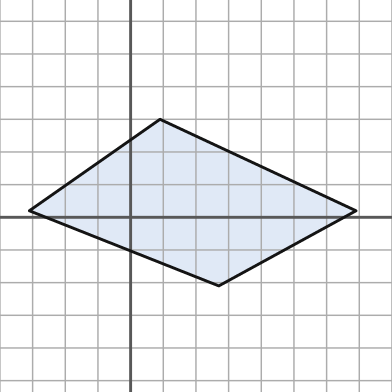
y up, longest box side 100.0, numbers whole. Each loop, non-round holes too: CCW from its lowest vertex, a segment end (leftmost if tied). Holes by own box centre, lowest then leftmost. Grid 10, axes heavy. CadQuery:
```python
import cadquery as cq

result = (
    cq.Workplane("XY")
    .moveTo(27.0, -21.0)
    .lineTo(69.0, 2.0)
    .lineTo(9.0, 30.0)
    .lineTo(-31.0, 2.0)
    .close()
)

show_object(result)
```